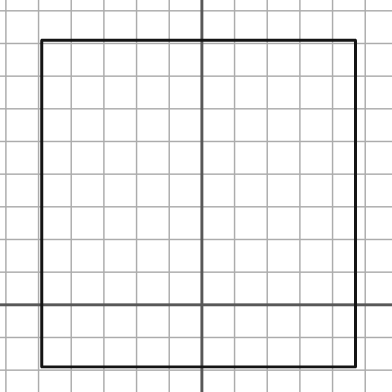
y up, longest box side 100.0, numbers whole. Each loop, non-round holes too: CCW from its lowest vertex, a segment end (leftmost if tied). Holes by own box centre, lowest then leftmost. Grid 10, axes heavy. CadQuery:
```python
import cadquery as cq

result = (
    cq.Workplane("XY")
    .moveTo(-49.0, -19.0)
    .lineTo(47.0, -19.0)
    .lineTo(47.0, 81.0)
    .lineTo(-49.0, 81.0)
    .close()
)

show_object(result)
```